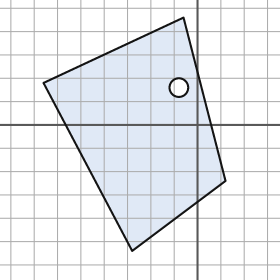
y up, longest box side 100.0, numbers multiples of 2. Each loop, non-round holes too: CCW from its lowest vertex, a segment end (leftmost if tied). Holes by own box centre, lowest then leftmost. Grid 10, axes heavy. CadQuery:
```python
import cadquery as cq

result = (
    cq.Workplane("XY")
    .moveTo(-28.0, -54.0)
    .lineTo(12.0, -24.0)
    .lineTo(-6.0, 46.0)
    .lineTo(-66.0, 18.0)
    .close()
    .moveTo(-8.0, 16.0)
    .circle(4.0)
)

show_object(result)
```